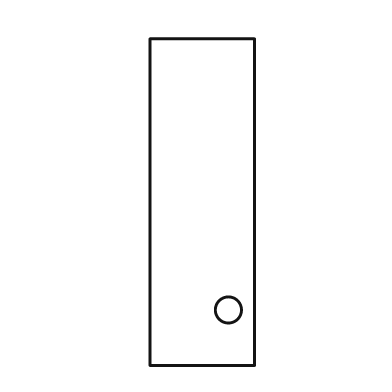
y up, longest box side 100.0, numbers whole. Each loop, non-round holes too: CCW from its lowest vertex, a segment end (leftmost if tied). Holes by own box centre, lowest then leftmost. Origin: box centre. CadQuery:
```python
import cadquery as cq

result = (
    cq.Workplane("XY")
    .moveTo(-16.0, -50.0)
    .lineTo(16.0, -50.0)
    .lineTo(16.0, 50.0)
    .lineTo(-16.0, 50.0)
    .close()
    .moveTo(8.0, -33.0)
    .circle(4.0)
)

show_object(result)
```